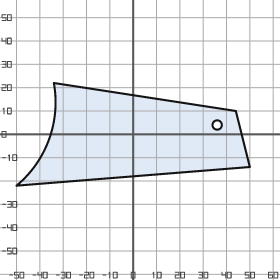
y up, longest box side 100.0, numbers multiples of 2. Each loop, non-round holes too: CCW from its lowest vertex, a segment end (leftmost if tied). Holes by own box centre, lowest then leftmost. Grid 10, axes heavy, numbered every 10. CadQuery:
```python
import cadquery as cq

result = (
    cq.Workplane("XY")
    .moveTo(-50.0, -22.0)
    .lineTo(50.0, -14.0)
    .lineTo(44.0, 10.0)
    .lineTo(-34.0, 22.0)
    .threePointArc((-36.0, -2.0), (-50.0, -22.0))
    .close()
    .moveTo(36.0, 4.0)
    .circle(2.0)
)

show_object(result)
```